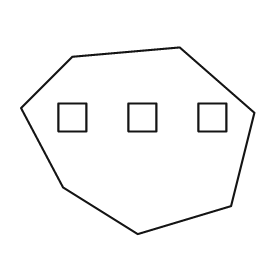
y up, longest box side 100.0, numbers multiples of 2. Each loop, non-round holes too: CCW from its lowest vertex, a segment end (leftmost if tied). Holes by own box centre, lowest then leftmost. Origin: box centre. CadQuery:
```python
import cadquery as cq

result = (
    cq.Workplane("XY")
    .moveTo(0.0, -40.0)
    .lineTo(40.0, -28.0)
    .lineTo(50.0, 12.0)
    .lineTo(18.0, 40.0)
    .lineTo(-28.0, 36.0)
    .lineTo(-50.0, 14.0)
    .lineTo(-32.0, -20.0)
    .close()
    .moveTo(-34.0, 4.0)
    .lineTo(-22.0, 4.0)
    .lineTo(-22.0, 16.0)
    .lineTo(-34.0, 16.0)
    .close()
    .moveTo(-4.0, 4.0)
    .lineTo(8.0, 4.0)
    .lineTo(8.0, 16.0)
    .lineTo(-4.0, 16.0)
    .close()
    .moveTo(26.0, 4.0)
    .lineTo(38.0, 4.0)
    .lineTo(38.0, 16.0)
    .lineTo(26.0, 16.0)
    .close()
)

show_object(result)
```